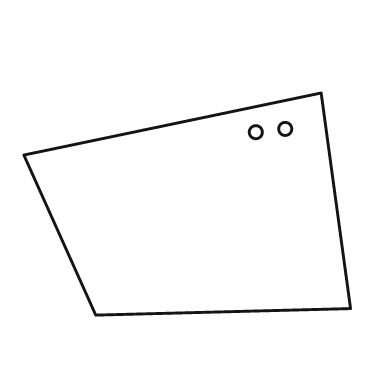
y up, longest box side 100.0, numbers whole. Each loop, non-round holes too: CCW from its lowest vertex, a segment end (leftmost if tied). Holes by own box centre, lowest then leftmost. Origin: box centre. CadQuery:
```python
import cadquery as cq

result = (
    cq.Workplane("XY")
    .moveTo(-28.0, -34.0)
    .lineTo(50.0, -32.0)
    .lineTo(41.0, 34.0)
    .lineTo(-50.0, 15.0)
    .close()
    .moveTo(21.0, 22.0)
    .circle(2.0)
    .moveTo(30.0, 23.0)
    .circle(2.0)
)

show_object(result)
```